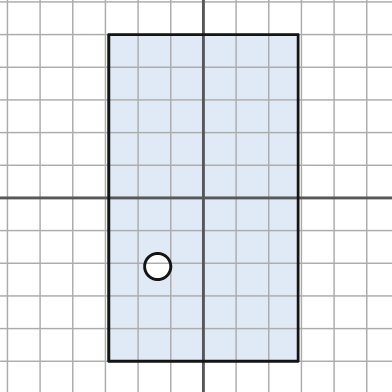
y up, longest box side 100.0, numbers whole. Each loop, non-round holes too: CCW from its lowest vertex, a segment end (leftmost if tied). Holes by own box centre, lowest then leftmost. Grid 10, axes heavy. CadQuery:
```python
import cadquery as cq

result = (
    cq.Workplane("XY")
    .moveTo(-29.0, -50.0)
    .lineTo(29.0, -50.0)
    .lineTo(29.0, 50.0)
    .lineTo(-29.0, 50.0)
    .close()
    .moveTo(-14.0, -21.0)
    .circle(4.0)
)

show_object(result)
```